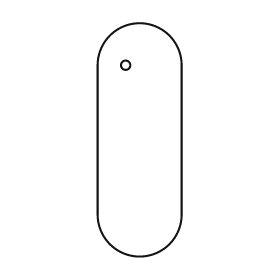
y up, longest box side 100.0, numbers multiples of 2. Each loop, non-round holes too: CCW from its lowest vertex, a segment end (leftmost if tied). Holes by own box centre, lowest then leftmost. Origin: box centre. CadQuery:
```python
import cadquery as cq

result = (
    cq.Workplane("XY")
    .moveTo(-18.0, -32.0)
    .threePointArc((0.0, -50.0), (18.0, -32.0))
    .lineTo(18.0, 32.0)
    .threePointArc((0.0, 50.0), (-18.0, 32.0))
    .close()
    .moveTo(-6.0, 32.0)
    .circle(2.0)
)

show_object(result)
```